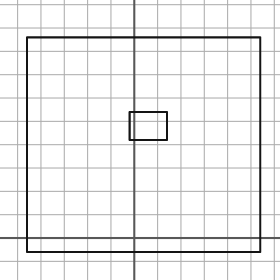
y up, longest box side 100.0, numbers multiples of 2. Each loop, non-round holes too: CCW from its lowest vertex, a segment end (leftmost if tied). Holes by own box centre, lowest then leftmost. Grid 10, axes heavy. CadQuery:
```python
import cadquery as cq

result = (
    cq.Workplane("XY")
    .moveTo(-46.0, -6.0)
    .lineTo(54.0, -6.0)
    .lineTo(54.0, 86.0)
    .lineTo(-46.0, 86.0)
    .close()
    .moveTo(-2.0, 42.0)
    .lineTo(14.0, 42.0)
    .lineTo(14.0, 54.0)
    .lineTo(-2.0, 54.0)
    .close()
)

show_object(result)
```